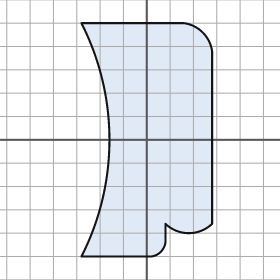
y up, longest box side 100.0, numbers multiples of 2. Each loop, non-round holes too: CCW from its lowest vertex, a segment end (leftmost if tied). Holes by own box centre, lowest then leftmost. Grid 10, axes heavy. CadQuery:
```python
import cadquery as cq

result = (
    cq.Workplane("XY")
    .moveTo(-28.0, -50.0)
    .lineTo(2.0, -50.0)
    .threePointArc((6.0, -48.0), (8.0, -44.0))
    .lineTo(8.0, -36.0)
    .threePointArc((18.0, -40.0), (28.0, -36.0))
    .lineTo(28.0, 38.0)
    .threePointArc((24.0, 46.0), (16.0, 50.0))
    .lineTo(-28.0, 50.0)
    .threePointArc((-16.0, 0.0), (-28.0, -50.0))
    .close()
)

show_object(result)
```